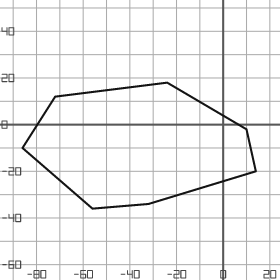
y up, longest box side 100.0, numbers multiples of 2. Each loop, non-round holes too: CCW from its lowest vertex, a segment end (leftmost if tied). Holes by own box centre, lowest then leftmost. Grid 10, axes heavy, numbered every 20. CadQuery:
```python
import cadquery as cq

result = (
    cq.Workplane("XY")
    .moveTo(-56.0, -36.0)
    .lineTo(-32.0, -34.0)
    .lineTo(14.0, -20.0)
    .lineTo(10.0, -2.0)
    .lineTo(-24.0, 18.0)
    .lineTo(-72.0, 12.0)
    .lineTo(-86.0, -10.0)
    .close()
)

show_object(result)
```